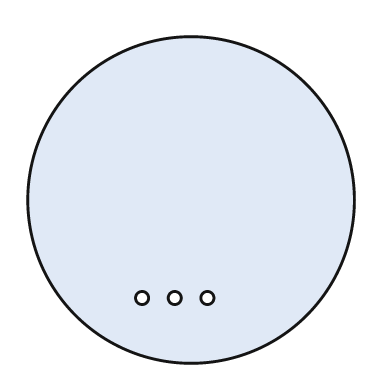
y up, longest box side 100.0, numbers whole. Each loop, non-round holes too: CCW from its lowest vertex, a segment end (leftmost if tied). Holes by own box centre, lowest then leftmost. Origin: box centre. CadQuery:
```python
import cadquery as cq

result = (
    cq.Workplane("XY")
    .moveTo(0.0, 0.0)
    .circle(50.0)
    .moveTo(-15.0, -30.0)
    .circle(2.0)
    .moveTo(-5.0, -30.0)
    .circle(2.0)
    .moveTo(5.0, -30.0)
    .circle(2.0)
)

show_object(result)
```